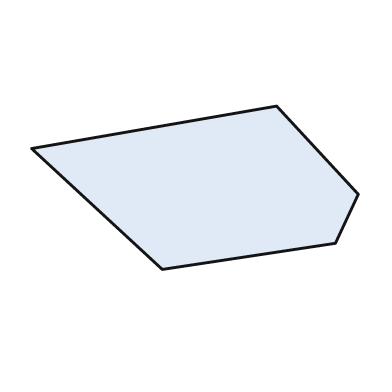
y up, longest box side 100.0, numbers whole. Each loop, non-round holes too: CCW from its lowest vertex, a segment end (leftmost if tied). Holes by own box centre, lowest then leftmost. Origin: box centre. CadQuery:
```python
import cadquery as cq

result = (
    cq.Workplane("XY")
    .moveTo(-10.0, -25.0)
    .lineTo(43.0, -17.0)
    .lineTo(50.0, -2.0)
    .lineTo(25.0, 25.0)
    .lineTo(-50.0, 12.0)
    .close()
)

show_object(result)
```